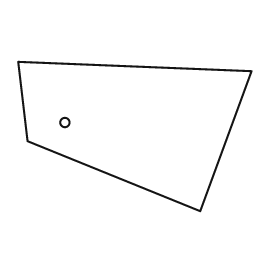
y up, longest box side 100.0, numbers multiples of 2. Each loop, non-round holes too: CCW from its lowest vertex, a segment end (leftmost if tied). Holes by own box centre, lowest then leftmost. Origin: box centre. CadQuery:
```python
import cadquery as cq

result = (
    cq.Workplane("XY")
    .moveTo(28.0, -32.0)
    .lineTo(50.0, 28.0)
    .lineTo(-50.0, 32.0)
    .lineTo(-46.0, -2.0)
    .close()
    .moveTo(-30.0, 6.0)
    .circle(2.0)
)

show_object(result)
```